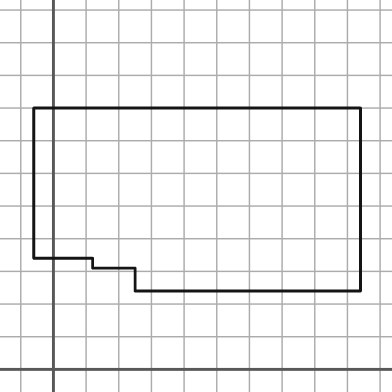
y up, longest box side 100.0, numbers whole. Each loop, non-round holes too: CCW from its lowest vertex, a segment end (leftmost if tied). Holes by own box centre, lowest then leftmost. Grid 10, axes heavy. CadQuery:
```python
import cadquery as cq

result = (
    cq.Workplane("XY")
    .moveTo(25.0, 24.0)
    .lineTo(94.0, 24.0)
    .lineTo(94.0, 80.0)
    .lineTo(-6.0, 80.0)
    .lineTo(-6.0, 34.0)
    .lineTo(12.0, 34.0)
    .lineTo(12.0, 31.0)
    .lineTo(25.0, 31.0)
    .close()
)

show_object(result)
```